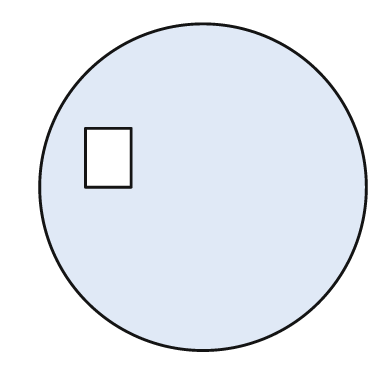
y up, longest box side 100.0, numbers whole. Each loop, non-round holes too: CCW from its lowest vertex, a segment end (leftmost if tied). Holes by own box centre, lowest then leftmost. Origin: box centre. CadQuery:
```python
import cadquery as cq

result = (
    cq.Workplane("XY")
    .moveTo(0.0, 0.0)
    .circle(50.0)
    .moveTo(-36.0, 0.0)
    .lineTo(-22.0, 0.0)
    .lineTo(-22.0, 18.0)
    .lineTo(-36.0, 18.0)
    .close()
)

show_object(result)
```